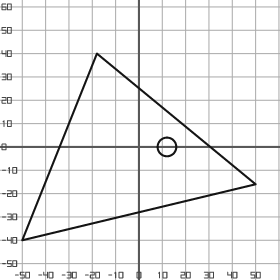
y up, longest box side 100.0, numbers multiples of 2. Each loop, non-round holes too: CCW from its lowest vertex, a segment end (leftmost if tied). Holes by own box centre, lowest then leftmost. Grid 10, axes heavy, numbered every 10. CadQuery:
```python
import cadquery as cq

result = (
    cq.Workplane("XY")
    .moveTo(-50.0, -40.0)
    .lineTo(50.0, -16.0)
    .lineTo(-18.0, 40.0)
    .close()
    .moveTo(12.0, 0.0)
    .circle(4.0)
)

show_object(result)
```